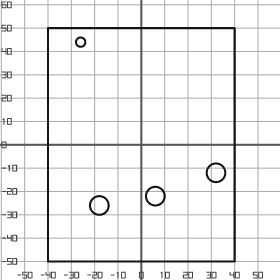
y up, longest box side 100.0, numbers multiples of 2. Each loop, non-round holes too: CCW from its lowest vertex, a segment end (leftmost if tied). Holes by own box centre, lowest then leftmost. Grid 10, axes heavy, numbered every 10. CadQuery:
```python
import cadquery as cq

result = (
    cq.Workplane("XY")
    .moveTo(-40.0, -50.0)
    .lineTo(40.0, -50.0)
    .lineTo(40.0, 50.0)
    .lineTo(-40.0, 50.0)
    .close()
    .moveTo(-18.0, -26.0)
    .circle(4.0)
    .moveTo(6.0, -22.0)
    .circle(4.0)
    .moveTo(32.0, -12.0)
    .circle(4.0)
    .moveTo(-26.0, 44.0)
    .circle(2.0)
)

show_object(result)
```